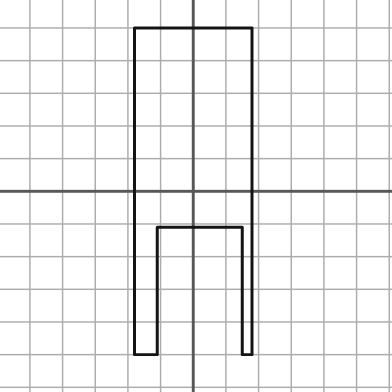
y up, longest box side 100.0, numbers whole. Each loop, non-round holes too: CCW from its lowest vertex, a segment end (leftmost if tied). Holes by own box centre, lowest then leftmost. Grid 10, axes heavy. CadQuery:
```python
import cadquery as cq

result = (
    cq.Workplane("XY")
    .moveTo(-18.0, -50.0)
    .lineTo(-11.0, -50.0)
    .lineTo(-11.0, -11.0)
    .lineTo(15.0, -11.0)
    .lineTo(15.0, -50.0)
    .lineTo(18.0, -50.0)
    .lineTo(18.0, 50.0)
    .lineTo(-18.0, 50.0)
    .close()
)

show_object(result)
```